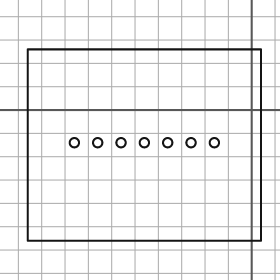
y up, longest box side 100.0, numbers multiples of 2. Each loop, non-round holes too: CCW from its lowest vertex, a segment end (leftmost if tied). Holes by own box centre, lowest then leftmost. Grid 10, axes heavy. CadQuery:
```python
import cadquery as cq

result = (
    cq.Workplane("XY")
    .moveTo(-96.0, -56.0)
    .lineTo(4.0, -56.0)
    .lineTo(4.0, 26.0)
    .lineTo(-96.0, 26.0)
    .close()
    .moveTo(-76.0, -14.0)
    .circle(2.0)
    .moveTo(-66.0, -14.0)
    .circle(2.0)
    .moveTo(-56.0, -14.0)
    .circle(2.0)
    .moveTo(-46.0, -14.0)
    .circle(2.0)
    .moveTo(-36.0, -14.0)
    .circle(2.0)
    .moveTo(-26.0, -14.0)
    .circle(2.0)
    .moveTo(-16.0, -14.0)
    .circle(2.0)
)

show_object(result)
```